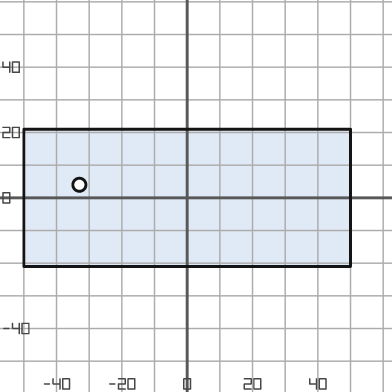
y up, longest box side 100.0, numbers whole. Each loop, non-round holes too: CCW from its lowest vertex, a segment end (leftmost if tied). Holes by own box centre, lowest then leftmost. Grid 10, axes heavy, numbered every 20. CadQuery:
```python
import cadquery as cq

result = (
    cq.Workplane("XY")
    .moveTo(-50.0, -21.0)
    .lineTo(50.0, -21.0)
    .lineTo(50.0, 21.0)
    .lineTo(-50.0, 21.0)
    .close()
    .moveTo(-33.0, 4.0)
    .circle(2.0)
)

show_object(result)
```